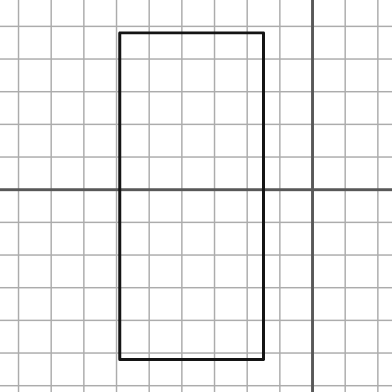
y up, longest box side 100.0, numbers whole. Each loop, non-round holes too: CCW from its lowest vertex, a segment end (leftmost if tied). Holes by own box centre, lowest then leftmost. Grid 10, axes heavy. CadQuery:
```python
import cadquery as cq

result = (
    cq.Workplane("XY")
    .moveTo(-59.0, -52.0)
    .lineTo(-15.0, -52.0)
    .lineTo(-15.0, 48.0)
    .lineTo(-59.0, 48.0)
    .close()
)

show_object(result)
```